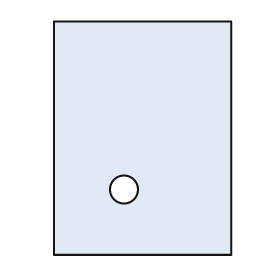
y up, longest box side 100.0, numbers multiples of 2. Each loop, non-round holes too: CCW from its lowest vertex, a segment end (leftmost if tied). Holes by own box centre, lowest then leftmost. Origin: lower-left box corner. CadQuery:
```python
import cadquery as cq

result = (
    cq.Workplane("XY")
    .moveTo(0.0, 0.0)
    .lineTo(76.0, 0.0)
    .lineTo(76.0, 100.0)
    .lineTo(0.0, 100.0)
    .close()
    .moveTo(30.0, 28.0)
    .circle(6.0)
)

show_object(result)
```